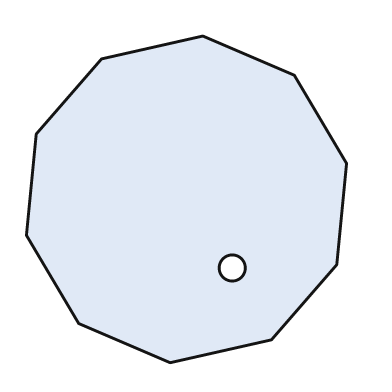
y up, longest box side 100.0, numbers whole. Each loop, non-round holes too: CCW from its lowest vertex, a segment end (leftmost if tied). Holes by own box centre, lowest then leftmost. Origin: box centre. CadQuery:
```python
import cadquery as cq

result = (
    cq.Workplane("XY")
    .moveTo(-5.0, -50.0)
    .lineTo(26.0, -43.0)
    .lineTo(46.0, -20.0)
    .lineTo(49.0, 11.0)
    .lineTo(33.0, 38.0)
    .lineTo(5.0, 50.0)
    .lineTo(-26.0, 43.0)
    .lineTo(-46.0, 20.0)
    .lineTo(-49.0, -11.0)
    .lineTo(-33.0, -38.0)
    .close()
    .moveTo(14.0, -21.0)
    .circle(4.0)
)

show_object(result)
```